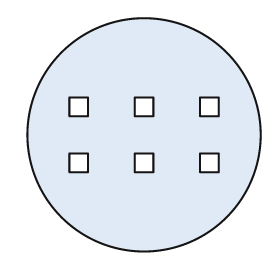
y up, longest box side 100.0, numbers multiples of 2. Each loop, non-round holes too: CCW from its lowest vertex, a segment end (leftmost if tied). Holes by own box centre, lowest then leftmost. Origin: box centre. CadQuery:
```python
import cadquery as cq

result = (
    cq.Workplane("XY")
    .moveTo(0.0, 0.0)
    .circle(50.0)
    .moveTo(-32.0, -16.0)
    .lineTo(-24.0, -16.0)
    .lineTo(-24.0, -8.0)
    .lineTo(-32.0, -8.0)
    .close()
    .moveTo(-4.0, -16.0)
    .lineTo(4.0, -16.0)
    .lineTo(4.0, -8.0)
    .lineTo(-4.0, -8.0)
    .close()
    .moveTo(24.0, -16.0)
    .lineTo(32.0, -16.0)
    .lineTo(32.0, -8.0)
    .lineTo(24.0, -8.0)
    .close()
    .moveTo(-32.0, 8.0)
    .lineTo(-24.0, 8.0)
    .lineTo(-24.0, 16.0)
    .lineTo(-32.0, 16.0)
    .close()
    .moveTo(-4.0, 8.0)
    .lineTo(4.0, 8.0)
    .lineTo(4.0, 16.0)
    .lineTo(-4.0, 16.0)
    .close()
    .moveTo(24.0, 8.0)
    .lineTo(32.0, 8.0)
    .lineTo(32.0, 16.0)
    .lineTo(24.0, 16.0)
    .close()
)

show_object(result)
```